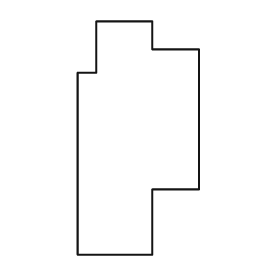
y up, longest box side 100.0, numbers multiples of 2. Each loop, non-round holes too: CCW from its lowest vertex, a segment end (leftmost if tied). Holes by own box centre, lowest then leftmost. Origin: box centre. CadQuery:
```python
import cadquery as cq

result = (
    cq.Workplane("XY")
    .moveTo(-26.0, -50.0)
    .lineTo(6.0, -50.0)
    .lineTo(6.0, -22.0)
    .lineTo(26.0, -22.0)
    .lineTo(26.0, 38.0)
    .lineTo(6.0, 38.0)
    .lineTo(6.0, 50.0)
    .lineTo(-18.0, 50.0)
    .lineTo(-18.0, 28.0)
    .lineTo(-26.0, 28.0)
    .close()
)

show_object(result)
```